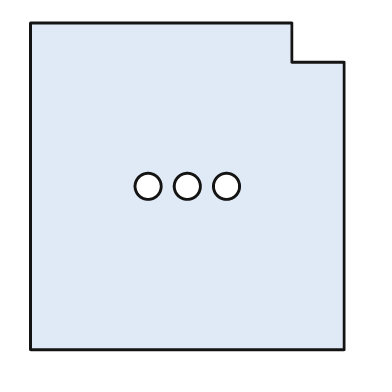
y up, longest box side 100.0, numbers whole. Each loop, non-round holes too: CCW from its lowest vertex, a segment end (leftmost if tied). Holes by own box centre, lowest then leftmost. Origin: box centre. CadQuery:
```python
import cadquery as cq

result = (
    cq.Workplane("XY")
    .moveTo(-48.0, -50.0)
    .lineTo(48.0, -50.0)
    .lineTo(48.0, 38.0)
    .lineTo(32.0, 38.0)
    .lineTo(32.0, 50.0)
    .lineTo(-48.0, 50.0)
    .close()
    .moveTo(-12.0, 0.0)
    .circle(4.0)
    .moveTo(0.0, 0.0)
    .circle(4.0)
    .moveTo(12.0, 0.0)
    .circle(4.0)
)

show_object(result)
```